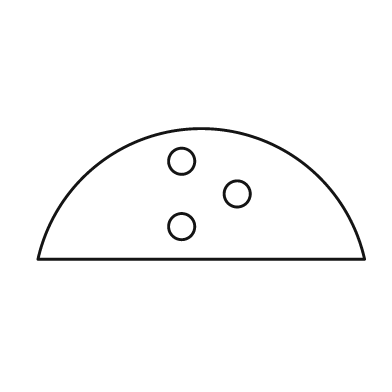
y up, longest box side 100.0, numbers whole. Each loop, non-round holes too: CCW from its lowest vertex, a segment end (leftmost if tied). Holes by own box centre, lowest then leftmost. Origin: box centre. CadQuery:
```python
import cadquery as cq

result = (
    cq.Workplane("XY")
    .moveTo(-50.0, -20.0)
    .lineTo(50.0, -20.0)
    .threePointArc((0.0, 20.0), (-50.0, -20.0))
    .close()
    .moveTo(-6.0, -10.0)
    .circle(4.0)
    .moveTo(11.0, 0.0)
    .circle(4.0)
    .moveTo(-6.0, 10.0)
    .circle(4.0)
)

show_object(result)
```